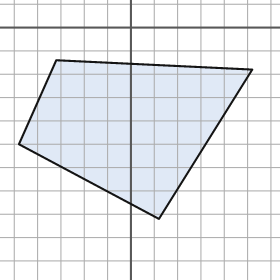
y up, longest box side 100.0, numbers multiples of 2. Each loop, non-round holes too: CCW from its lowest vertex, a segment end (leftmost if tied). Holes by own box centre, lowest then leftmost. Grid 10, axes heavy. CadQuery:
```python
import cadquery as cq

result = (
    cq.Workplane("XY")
    .moveTo(12.0, -82.0)
    .lineTo(52.0, -18.0)
    .lineTo(-32.0, -14.0)
    .lineTo(-48.0, -50.0)
    .close()
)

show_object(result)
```